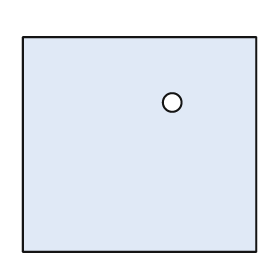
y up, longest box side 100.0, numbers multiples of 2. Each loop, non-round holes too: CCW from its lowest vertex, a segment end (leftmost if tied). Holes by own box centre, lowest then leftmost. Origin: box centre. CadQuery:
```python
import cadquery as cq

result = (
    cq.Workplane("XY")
    .moveTo(-50.0, -46.0)
    .lineTo(50.0, -46.0)
    .lineTo(50.0, 46.0)
    .lineTo(-50.0, 46.0)
    .close()
    .moveTo(14.0, 18.0)
    .circle(4.0)
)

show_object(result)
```